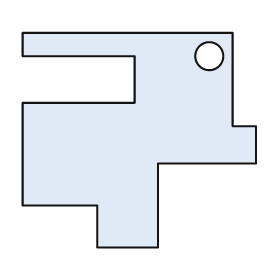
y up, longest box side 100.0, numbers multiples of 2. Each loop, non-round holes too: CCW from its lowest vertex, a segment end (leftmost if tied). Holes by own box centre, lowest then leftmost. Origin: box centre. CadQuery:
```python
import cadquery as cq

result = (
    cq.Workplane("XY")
    .moveTo(-18.0, -46.0)
    .lineTo(8.0, -46.0)
    .lineTo(8.0, -10.0)
    .lineTo(50.0, -10.0)
    .lineTo(50.0, 6.0)
    .lineTo(40.0, 6.0)
    .lineTo(40.0, 46.0)
    .lineTo(-50.0, 46.0)
    .lineTo(-50.0, 36.0)
    .lineTo(-2.0, 36.0)
    .lineTo(-2.0, 16.0)
    .lineTo(-50.0, 16.0)
    .lineTo(-50.0, -28.0)
    .lineTo(-18.0, -28.0)
    .close()
    .moveTo(30.0, 36.0)
    .circle(6.0)
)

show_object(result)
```